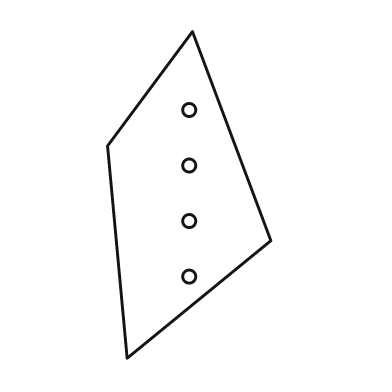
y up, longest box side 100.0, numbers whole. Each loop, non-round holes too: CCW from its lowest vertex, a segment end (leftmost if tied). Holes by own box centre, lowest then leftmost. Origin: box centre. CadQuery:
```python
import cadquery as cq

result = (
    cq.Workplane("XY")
    .moveTo(-19.0, -50.0)
    .lineTo(25.0, -14.0)
    .lineTo(1.0, 50.0)
    .lineTo(-25.0, 15.0)
    .close()
    .moveTo(0.0, -25.0)
    .circle(2.0)
    .moveTo(0.0, -8.0)
    .circle(2.0)
    .moveTo(0.0, 9.0)
    .circle(2.0)
    .moveTo(0.0, 26.0)
    .circle(2.0)
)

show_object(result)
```